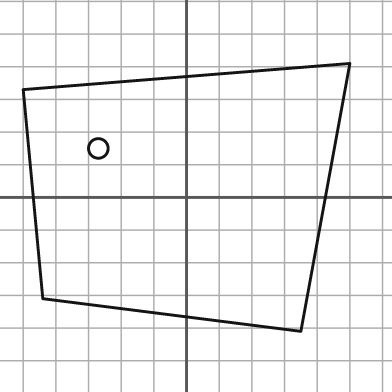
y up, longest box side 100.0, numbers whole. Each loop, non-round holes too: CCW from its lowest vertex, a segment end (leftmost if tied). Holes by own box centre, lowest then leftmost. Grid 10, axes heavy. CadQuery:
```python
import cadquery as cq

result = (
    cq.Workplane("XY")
    .moveTo(35.0, -41.0)
    .lineTo(50.0, 41.0)
    .lineTo(-50.0, 33.0)
    .lineTo(-44.0, -31.0)
    .close()
    .moveTo(-27.0, 15.0)
    .circle(3.0)
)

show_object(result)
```